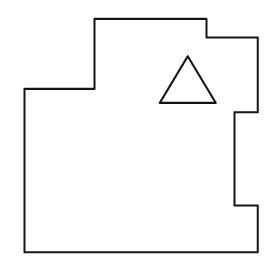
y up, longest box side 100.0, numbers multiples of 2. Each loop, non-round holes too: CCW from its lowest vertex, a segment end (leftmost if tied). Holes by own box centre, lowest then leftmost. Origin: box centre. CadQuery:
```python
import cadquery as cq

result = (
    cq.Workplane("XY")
    .moveTo(-50.0, -50.0)
    .lineTo(50.0, -50.0)
    .lineTo(50.0, -30.0)
    .lineTo(40.0, -30.0)
    .lineTo(40.0, 10.0)
    .lineTo(50.0, 10.0)
    .lineTo(50.0, 42.0)
    .lineTo(28.0, 42.0)
    .lineTo(28.0, 50.0)
    .lineTo(-20.0, 50.0)
    .lineTo(-20.0, 20.0)
    .lineTo(-50.0, 20.0)
    .close()
    .moveTo(8.0, 14.0)
    .lineTo(32.0, 14.0)
    .lineTo(20.0, 34.0)
    .close()
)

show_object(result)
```